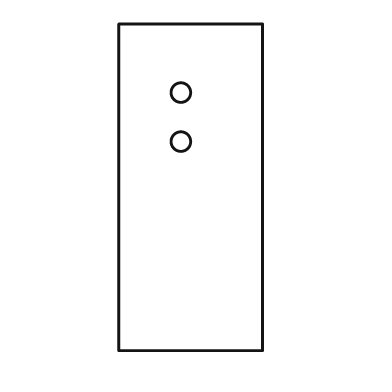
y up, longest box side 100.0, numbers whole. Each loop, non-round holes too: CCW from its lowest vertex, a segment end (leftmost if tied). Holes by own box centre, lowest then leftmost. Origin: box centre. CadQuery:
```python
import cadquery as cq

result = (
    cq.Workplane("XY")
    .moveTo(-22.0, -50.0)
    .lineTo(22.0, -50.0)
    .lineTo(22.0, 50.0)
    .lineTo(-22.0, 50.0)
    .close()
    .moveTo(-3.0, 14.0)
    .circle(3.0)
    .moveTo(-3.0, 29.0)
    .circle(3.0)
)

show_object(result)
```